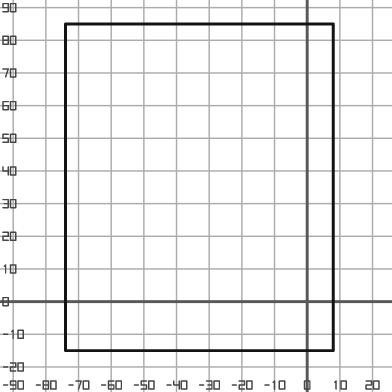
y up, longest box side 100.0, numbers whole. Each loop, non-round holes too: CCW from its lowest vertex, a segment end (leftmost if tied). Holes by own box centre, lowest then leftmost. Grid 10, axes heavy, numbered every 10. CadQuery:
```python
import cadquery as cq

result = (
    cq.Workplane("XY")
    .moveTo(-74.0, -15.0)
    .lineTo(8.0, -15.0)
    .lineTo(8.0, 85.0)
    .lineTo(-74.0, 85.0)
    .close()
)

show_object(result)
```